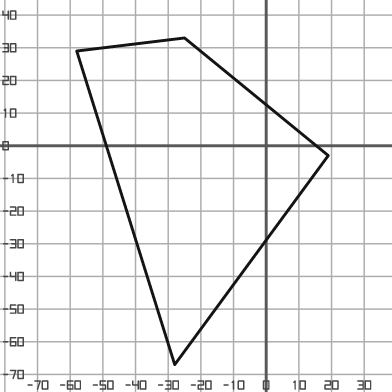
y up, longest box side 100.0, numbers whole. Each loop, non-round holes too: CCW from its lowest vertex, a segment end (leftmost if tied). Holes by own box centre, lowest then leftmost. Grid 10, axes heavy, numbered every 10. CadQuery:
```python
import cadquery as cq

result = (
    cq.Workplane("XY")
    .moveTo(-28.0, -67.0)
    .lineTo(19.0, -3.0)
    .lineTo(-25.0, 33.0)
    .lineTo(-58.0, 29.0)
    .close()
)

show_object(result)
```